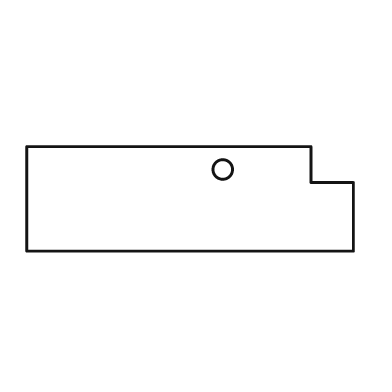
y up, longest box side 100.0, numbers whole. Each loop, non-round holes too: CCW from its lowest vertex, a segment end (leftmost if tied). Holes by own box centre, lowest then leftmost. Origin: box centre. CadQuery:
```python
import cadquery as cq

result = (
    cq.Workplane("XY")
    .moveTo(-50.0, -16.0)
    .lineTo(50.0, -16.0)
    .lineTo(50.0, 5.0)
    .lineTo(37.0, 5.0)
    .lineTo(37.0, 16.0)
    .lineTo(-50.0, 16.0)
    .close()
    .moveTo(10.0, 9.0)
    .circle(3.0)
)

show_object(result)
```